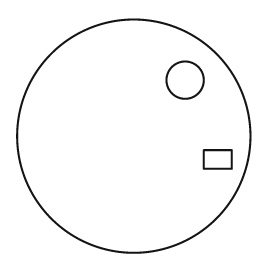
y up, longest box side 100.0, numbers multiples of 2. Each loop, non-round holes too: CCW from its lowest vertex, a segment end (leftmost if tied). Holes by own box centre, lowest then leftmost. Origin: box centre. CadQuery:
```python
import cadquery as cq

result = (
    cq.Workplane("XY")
    .moveTo(0.0, 0.0)
    .circle(50.0)
    .moveTo(30.0, -14.0)
    .lineTo(42.0, -14.0)
    .lineTo(42.0, -6.0)
    .lineTo(30.0, -6.0)
    .close()
    .moveTo(22.0, 24.0)
    .circle(8.0)
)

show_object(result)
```